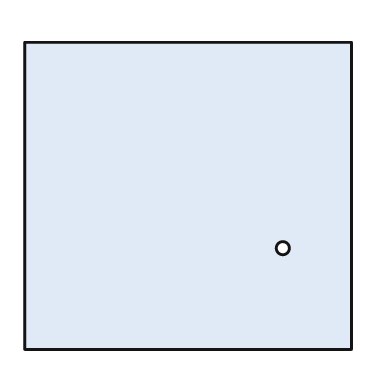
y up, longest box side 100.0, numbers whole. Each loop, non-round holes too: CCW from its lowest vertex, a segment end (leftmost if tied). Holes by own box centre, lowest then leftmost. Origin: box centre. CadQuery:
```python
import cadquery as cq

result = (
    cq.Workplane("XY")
    .moveTo(-50.0, -47.0)
    .lineTo(50.0, -47.0)
    .lineTo(50.0, 47.0)
    .lineTo(-50.0, 47.0)
    .close()
    .moveTo(29.0, -16.0)
    .circle(2.0)
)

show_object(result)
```